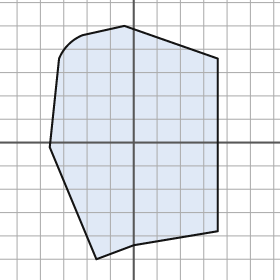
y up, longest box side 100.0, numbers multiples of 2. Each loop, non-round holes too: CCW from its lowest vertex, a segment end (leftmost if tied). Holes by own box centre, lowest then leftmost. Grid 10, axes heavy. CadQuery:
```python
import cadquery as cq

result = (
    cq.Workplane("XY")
    .moveTo(-16.0, -50.0)
    .lineTo(0.0, -44.0)
    .lineTo(36.0, -38.0)
    .lineTo(36.0, 36.0)
    .lineTo(-4.0, 50.0)
    .lineTo(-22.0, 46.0)
    .threePointArc((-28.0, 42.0), (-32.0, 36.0))
    .lineTo(-36.0, -2.0)
    .close()
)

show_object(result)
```